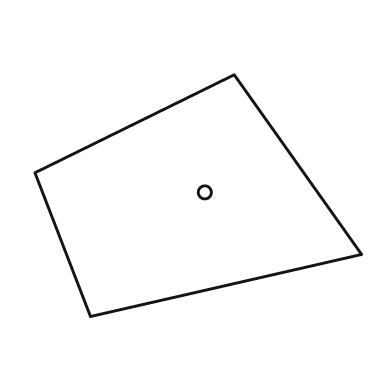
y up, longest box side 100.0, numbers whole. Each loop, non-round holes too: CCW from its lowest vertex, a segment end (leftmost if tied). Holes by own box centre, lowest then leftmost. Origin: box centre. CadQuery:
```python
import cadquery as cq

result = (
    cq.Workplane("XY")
    .moveTo(-33.0, -37.0)
    .lineTo(50.0, -18.0)
    .lineTo(11.0, 37.0)
    .lineTo(-50.0, 7.0)
    .close()
    .moveTo(2.0, 1.0)
    .circle(2.0)
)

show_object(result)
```